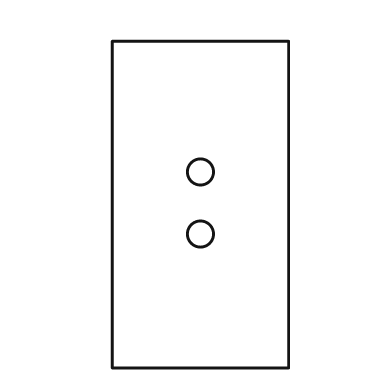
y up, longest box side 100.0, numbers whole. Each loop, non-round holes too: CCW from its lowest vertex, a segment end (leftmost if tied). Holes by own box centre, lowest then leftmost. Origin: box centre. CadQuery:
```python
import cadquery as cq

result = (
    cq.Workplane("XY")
    .moveTo(-27.0, -50.0)
    .lineTo(27.0, -50.0)
    .lineTo(27.0, 50.0)
    .lineTo(-27.0, 50.0)
    .close()
    .moveTo(0.0, -9.0)
    .circle(4.0)
    .moveTo(0.0, 10.0)
    .circle(4.0)
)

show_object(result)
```